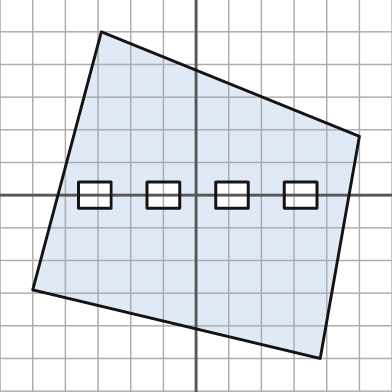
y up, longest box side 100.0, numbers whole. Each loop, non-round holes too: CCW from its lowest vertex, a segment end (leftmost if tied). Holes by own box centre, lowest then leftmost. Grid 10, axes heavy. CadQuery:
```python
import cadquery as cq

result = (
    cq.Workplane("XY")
    .moveTo(38.0, -50.0)
    .lineTo(50.0, 18.0)
    .lineTo(-29.0, 50.0)
    .lineTo(-50.0, -29.0)
    .close()
    .moveTo(-36.0, -4.0)
    .lineTo(-26.0, -4.0)
    .lineTo(-26.0, 4.0)
    .lineTo(-36.0, 4.0)
    .close()
    .moveTo(-15.0, -4.0)
    .lineTo(-5.0, -4.0)
    .lineTo(-5.0, 4.0)
    .lineTo(-15.0, 4.0)
    .close()
    .moveTo(6.0, -4.0)
    .lineTo(16.0, -4.0)
    .lineTo(16.0, 4.0)
    .lineTo(6.0, 4.0)
    .close()
    .moveTo(27.0, -4.0)
    .lineTo(37.0, -4.0)
    .lineTo(37.0, 4.0)
    .lineTo(27.0, 4.0)
    .close()
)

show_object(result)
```